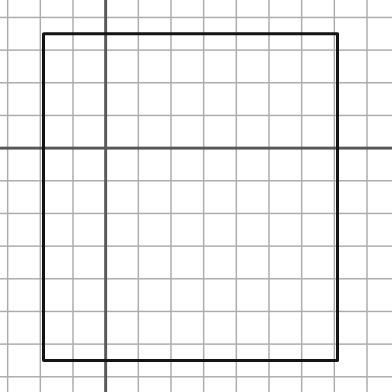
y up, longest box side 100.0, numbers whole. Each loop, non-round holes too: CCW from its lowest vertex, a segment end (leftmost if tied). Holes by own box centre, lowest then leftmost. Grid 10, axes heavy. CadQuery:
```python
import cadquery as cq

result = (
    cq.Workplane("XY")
    .moveTo(-19.0, -65.0)
    .lineTo(71.0, -65.0)
    .lineTo(71.0, 35.0)
    .lineTo(-19.0, 35.0)
    .close()
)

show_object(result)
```